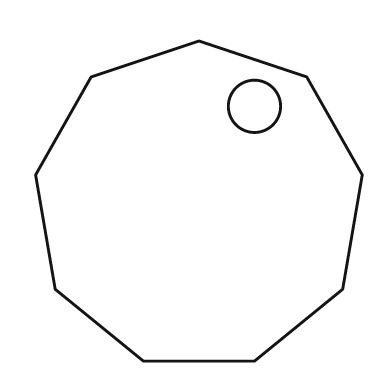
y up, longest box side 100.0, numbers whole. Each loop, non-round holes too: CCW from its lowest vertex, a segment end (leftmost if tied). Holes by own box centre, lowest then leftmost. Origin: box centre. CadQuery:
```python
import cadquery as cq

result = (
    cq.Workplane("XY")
    .moveTo(-17.0, -49.0)
    .lineTo(17.0, -49.0)
    .lineTo(44.0, -27.0)
    .lineTo(50.0, 8.0)
    .lineTo(33.0, 38.0)
    .lineTo(0.0, 49.0)
    .lineTo(-33.0, 38.0)
    .lineTo(-50.0, 8.0)
    .lineTo(-44.0, -27.0)
    .close()
    .moveTo(17.0, 29.0)
    .circle(8.0)
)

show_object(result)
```